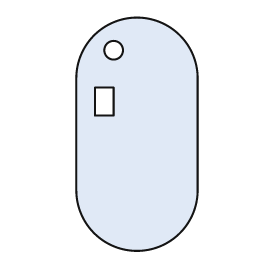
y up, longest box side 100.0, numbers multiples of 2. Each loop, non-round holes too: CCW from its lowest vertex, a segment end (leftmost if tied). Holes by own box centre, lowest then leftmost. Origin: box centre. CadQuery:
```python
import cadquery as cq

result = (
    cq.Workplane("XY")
    .moveTo(-26.0, -24.0)
    .threePointArc((0.0, -50.0), (26.0, -24.0))
    .lineTo(26.0, 24.0)
    .threePointArc((0.0, 50.0), (-26.0, 24.0))
    .close()
    .moveTo(-18.0, 8.0)
    .lineTo(-10.0, 8.0)
    .lineTo(-10.0, 20.0)
    .lineTo(-18.0, 20.0)
    .close()
    .moveTo(-10.0, 36.0)
    .circle(4.0)
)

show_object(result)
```